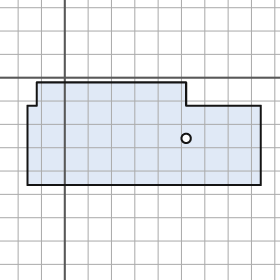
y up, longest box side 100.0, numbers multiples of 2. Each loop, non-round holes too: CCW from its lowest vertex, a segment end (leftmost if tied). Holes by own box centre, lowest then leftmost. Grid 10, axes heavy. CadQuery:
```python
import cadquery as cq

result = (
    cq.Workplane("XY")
    .moveTo(-16.0, -46.0)
    .lineTo(84.0, -46.0)
    .lineTo(84.0, -12.0)
    .lineTo(52.0, -12.0)
    .lineTo(52.0, -2.0)
    .lineTo(-12.0, -2.0)
    .lineTo(-12.0, -12.0)
    .lineTo(-16.0, -12.0)
    .close()
    .moveTo(52.0, -26.0)
    .circle(2.0)
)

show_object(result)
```